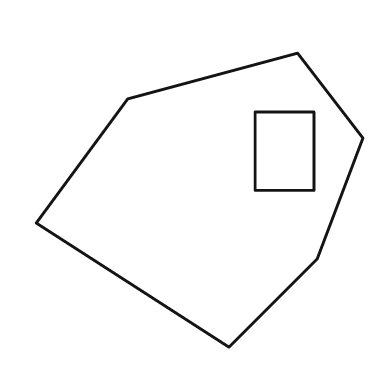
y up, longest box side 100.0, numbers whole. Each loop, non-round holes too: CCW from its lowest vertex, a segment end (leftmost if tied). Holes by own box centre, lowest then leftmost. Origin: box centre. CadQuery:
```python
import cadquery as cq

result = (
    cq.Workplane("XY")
    .moveTo(9.0, -45.0)
    .lineTo(36.0, -18.0)
    .lineTo(50.0, 19.0)
    .lineTo(30.0, 45.0)
    .lineTo(-22.0, 31.0)
    .lineTo(-50.0, -7.0)
    .close()
    .moveTo(17.0, 3.0)
    .lineTo(35.0, 3.0)
    .lineTo(35.0, 27.0)
    .lineTo(17.0, 27.0)
    .close()
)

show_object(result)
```